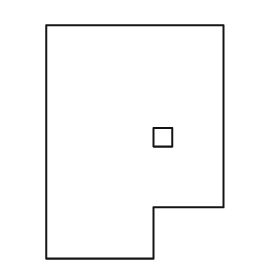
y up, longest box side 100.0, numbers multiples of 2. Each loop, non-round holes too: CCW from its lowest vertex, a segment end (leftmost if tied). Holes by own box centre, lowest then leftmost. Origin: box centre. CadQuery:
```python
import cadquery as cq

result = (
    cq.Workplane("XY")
    .moveTo(-38.0, -50.0)
    .lineTo(8.0, -50.0)
    .lineTo(8.0, -28.0)
    .lineTo(38.0, -28.0)
    .lineTo(38.0, 50.0)
    .lineTo(-38.0, 50.0)
    .close()
    .moveTo(8.0, -2.0)
    .lineTo(16.0, -2.0)
    .lineTo(16.0, 6.0)
    .lineTo(8.0, 6.0)
    .close()
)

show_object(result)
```